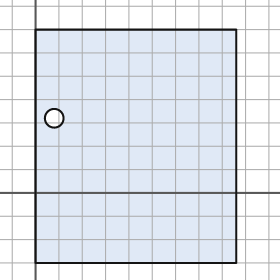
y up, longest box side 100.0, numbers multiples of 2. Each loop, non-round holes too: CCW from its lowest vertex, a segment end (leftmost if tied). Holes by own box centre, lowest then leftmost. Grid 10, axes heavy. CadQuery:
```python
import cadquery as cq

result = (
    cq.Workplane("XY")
    .moveTo(0.0, -30.0)
    .lineTo(86.0, -30.0)
    .lineTo(86.0, 70.0)
    .lineTo(0.0, 70.0)
    .close()
    .moveTo(8.0, 32.0)
    .circle(4.0)
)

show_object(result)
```